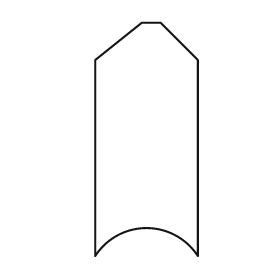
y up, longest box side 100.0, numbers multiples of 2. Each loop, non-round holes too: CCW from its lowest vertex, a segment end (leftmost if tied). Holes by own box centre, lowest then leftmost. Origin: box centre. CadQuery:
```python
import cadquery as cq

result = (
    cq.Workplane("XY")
    .moveTo(-22.0, -50.0)
    .threePointArc((0.0, -38.0), (22.0, -50.0))
    .lineTo(22.0, 34.0)
    .lineTo(6.0, 50.0)
    .lineTo(-2.0, 50.0)
    .lineTo(-22.0, 34.0)
    .close()
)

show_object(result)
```